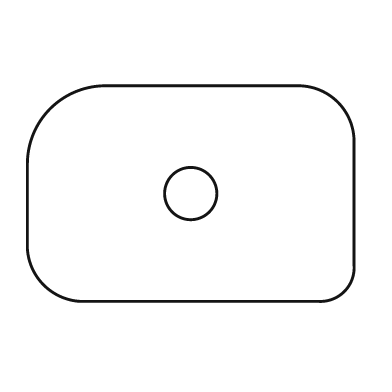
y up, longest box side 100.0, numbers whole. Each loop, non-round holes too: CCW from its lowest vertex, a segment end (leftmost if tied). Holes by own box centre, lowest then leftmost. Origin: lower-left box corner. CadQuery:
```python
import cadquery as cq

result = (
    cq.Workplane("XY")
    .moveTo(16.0, 0.0)
    .lineTo(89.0, 0.0)
    .threePointArc((97.0, 3.0), (100.0, 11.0))
    .lineTo(100.0, 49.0)
    .threePointArc((95.0, 61.0), (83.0, 66.0))
    .lineTo(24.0, 66.0)
    .threePointArc((7.0, 59.0), (0.0, 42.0))
    .lineTo(0.0, 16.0)
    .threePointArc((5.0, 5.0), (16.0, 0.0))
    .close()
    .moveTo(50.0, 33.0)
    .circle(8.0)
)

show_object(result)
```